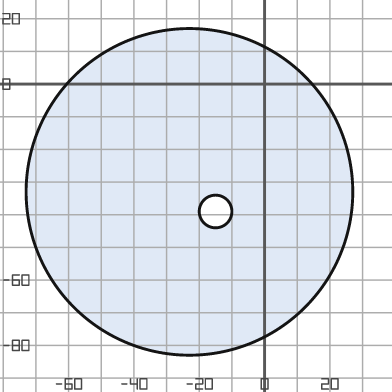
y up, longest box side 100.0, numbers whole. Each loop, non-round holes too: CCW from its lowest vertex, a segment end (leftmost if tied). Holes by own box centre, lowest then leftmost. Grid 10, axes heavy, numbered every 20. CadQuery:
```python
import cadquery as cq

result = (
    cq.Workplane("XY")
    .moveTo(-23.0, -33.0)
    .circle(50.0)
    .moveTo(-15.0, -39.0)
    .circle(5.0)
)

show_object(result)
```